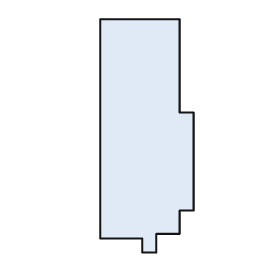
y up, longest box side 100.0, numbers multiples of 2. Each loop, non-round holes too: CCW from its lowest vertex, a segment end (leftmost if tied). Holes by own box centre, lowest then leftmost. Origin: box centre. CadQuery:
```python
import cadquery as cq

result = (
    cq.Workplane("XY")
    .moveTo(-2.0, -50.0)
    .lineTo(4.0, -50.0)
    .lineTo(4.0, -42.0)
    .lineTo(14.0, -42.0)
    .lineTo(14.0, -32.0)
    .lineTo(20.0, -32.0)
    .lineTo(20.0, 10.0)
    .lineTo(14.0, 10.0)
    .lineTo(14.0, 50.0)
    .lineTo(-20.0, 50.0)
    .lineTo(-20.0, -44.0)
    .lineTo(-2.0, -44.0)
    .close()
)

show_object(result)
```